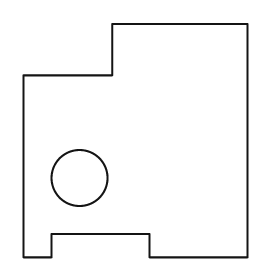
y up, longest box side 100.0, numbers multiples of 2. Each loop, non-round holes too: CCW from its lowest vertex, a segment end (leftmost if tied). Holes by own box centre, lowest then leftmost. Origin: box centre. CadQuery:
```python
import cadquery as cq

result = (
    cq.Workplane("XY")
    .moveTo(-48.0, -50.0)
    .lineTo(-36.0, -50.0)
    .lineTo(-36.0, -40.0)
    .lineTo(6.0, -40.0)
    .lineTo(6.0, -50.0)
    .lineTo(48.0, -50.0)
    .lineTo(48.0, 50.0)
    .lineTo(-10.0, 50.0)
    .lineTo(-10.0, 28.0)
    .lineTo(-48.0, 28.0)
    .close()
    .moveTo(-24.0, -16.0)
    .circle(12.0)
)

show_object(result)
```